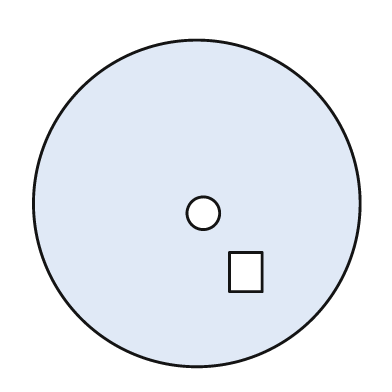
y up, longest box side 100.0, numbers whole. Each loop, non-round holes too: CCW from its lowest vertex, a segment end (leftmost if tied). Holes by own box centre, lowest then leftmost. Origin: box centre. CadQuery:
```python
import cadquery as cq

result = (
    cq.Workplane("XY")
    .moveTo(0.0, 0.0)
    .circle(50.0)
    .moveTo(10.0, -27.0)
    .lineTo(20.0, -27.0)
    .lineTo(20.0, -15.0)
    .lineTo(10.0, -15.0)
    .close()
    .moveTo(2.0, -3.0)
    .circle(5.0)
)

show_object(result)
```